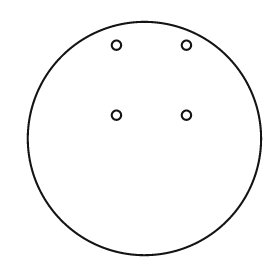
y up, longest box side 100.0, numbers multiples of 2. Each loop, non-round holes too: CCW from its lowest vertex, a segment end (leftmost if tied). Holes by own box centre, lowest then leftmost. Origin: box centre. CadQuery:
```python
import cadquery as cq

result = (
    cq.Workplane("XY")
    .moveTo(0.0, 0.0)
    .circle(50.0)
    .moveTo(-12.0, 10.0)
    .circle(2.0)
    .moveTo(18.0, 10.0)
    .circle(2.0)
    .moveTo(-12.0, 40.0)
    .circle(2.0)
    .moveTo(18.0, 40.0)
    .circle(2.0)
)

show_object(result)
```